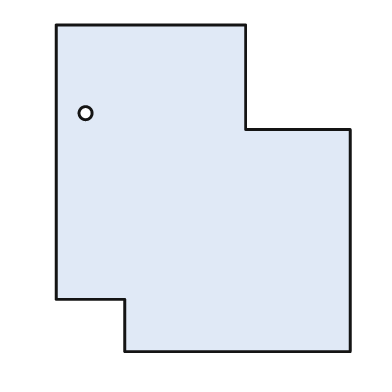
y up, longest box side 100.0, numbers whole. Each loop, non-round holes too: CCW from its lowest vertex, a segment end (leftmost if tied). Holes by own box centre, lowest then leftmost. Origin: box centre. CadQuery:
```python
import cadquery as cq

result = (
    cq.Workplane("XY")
    .moveTo(-24.0, -50.0)
    .lineTo(45.0, -50.0)
    .lineTo(45.0, 18.0)
    .lineTo(13.0, 18.0)
    .lineTo(13.0, 50.0)
    .lineTo(-45.0, 50.0)
    .lineTo(-45.0, -34.0)
    .lineTo(-24.0, -34.0)
    .close()
    .moveTo(-36.0, 23.0)
    .circle(2.0)
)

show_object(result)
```